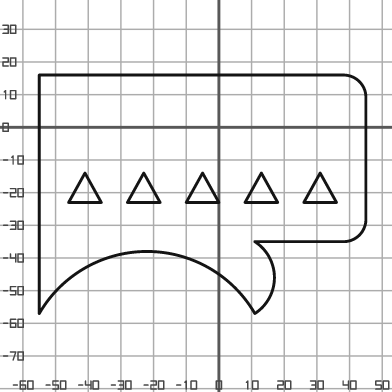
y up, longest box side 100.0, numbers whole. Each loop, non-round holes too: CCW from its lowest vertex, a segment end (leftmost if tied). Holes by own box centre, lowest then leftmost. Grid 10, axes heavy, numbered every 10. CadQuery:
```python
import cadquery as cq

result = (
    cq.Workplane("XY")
    .moveTo(-55.0, -57.0)
    .threePointArc((-22.0, -38.0), (11.0, -57.0))
    .threePointArc((17.0, -46.0), (11.0, -35.0))
    .lineTo(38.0, -35.0)
    .threePointArc((43.0, -33.0), (45.0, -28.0))
    .lineTo(45.0, 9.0)
    .threePointArc((43.0, 14.0), (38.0, 16.0))
    .lineTo(-55.0, 16.0)
    .close()
    .moveTo(-46.0, -23.0)
    .lineTo(-36.0, -23.0)
    .lineTo(-41.0, -14.0)
    .close()
    .moveTo(-28.0, -23.0)
    .lineTo(-18.0, -23.0)
    .lineTo(-23.0, -14.0)
    .close()
    .moveTo(-10.0, -23.0)
    .lineTo(0.0, -23.0)
    .lineTo(-5.0, -14.0)
    .close()
    .moveTo(8.0, -23.0)
    .lineTo(18.0, -23.0)
    .lineTo(13.0, -14.0)
    .close()
    .moveTo(26.0, -23.0)
    .lineTo(36.0, -23.0)
    .lineTo(31.0, -14.0)
    .close()
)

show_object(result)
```